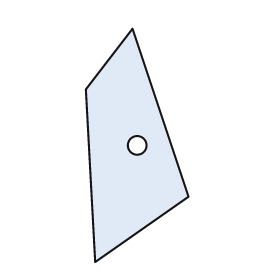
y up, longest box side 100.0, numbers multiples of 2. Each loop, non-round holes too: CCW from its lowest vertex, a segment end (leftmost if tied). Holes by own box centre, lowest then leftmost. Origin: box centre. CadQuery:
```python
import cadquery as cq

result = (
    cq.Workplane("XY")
    .moveTo(-18.0, -50.0)
    .lineTo(22.0, -22.0)
    .lineTo(-2.0, 50.0)
    .lineTo(-22.0, 24.0)
    .close()
    .moveTo(0.0, 0.0)
    .circle(4.0)
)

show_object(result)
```